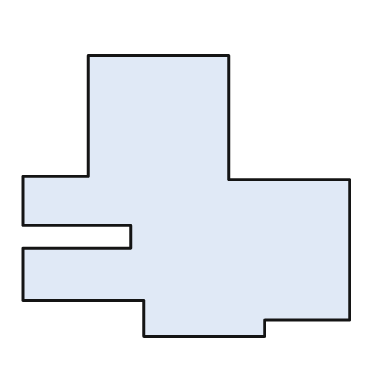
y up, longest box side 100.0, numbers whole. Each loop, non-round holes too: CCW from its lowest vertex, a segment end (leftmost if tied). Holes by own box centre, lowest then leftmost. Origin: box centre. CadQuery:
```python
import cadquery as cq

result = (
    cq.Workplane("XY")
    .moveTo(-13.0, -43.0)
    .lineTo(24.0, -43.0)
    .lineTo(24.0, -38.0)
    .lineTo(50.0, -38.0)
    .lineTo(50.0, 5.0)
    .lineTo(13.0, 5.0)
    .lineTo(13.0, 43.0)
    .lineTo(-30.0, 43.0)
    .lineTo(-30.0, 6.0)
    .lineTo(-50.0, 6.0)
    .lineTo(-50.0, -9.0)
    .lineTo(-17.0, -9.0)
    .lineTo(-17.0, -16.0)
    .lineTo(-50.0, -16.0)
    .lineTo(-50.0, -32.0)
    .lineTo(-13.0, -32.0)
    .close()
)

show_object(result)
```